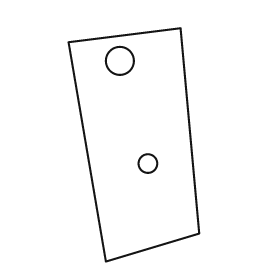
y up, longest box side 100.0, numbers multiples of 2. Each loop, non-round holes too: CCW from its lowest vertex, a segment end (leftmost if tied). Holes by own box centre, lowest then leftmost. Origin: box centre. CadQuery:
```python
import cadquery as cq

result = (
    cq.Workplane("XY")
    .moveTo(-12.0, -50.0)
    .lineTo(28.0, -38.0)
    .lineTo(20.0, 50.0)
    .lineTo(-28.0, 44.0)
    .close()
    .moveTo(6.0, -8.0)
    .circle(4.0)
    .moveTo(-6.0, 36.0)
    .circle(6.0)
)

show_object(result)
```